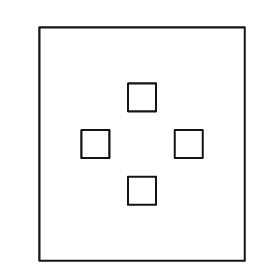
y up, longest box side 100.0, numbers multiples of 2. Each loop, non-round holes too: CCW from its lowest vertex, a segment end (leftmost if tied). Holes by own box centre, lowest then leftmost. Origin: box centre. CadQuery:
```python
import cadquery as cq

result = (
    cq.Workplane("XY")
    .moveTo(-44.0, -50.0)
    .lineTo(44.0, -50.0)
    .lineTo(44.0, 50.0)
    .lineTo(-44.0, 50.0)
    .close()
    .moveTo(-6.0, -26.0)
    .lineTo(6.0, -26.0)
    .lineTo(6.0, -14.0)
    .lineTo(-6.0, -14.0)
    .close()
    .moveTo(-26.0, -6.0)
    .lineTo(-14.0, -6.0)
    .lineTo(-14.0, 6.0)
    .lineTo(-26.0, 6.0)
    .close()
    .moveTo(14.0, -6.0)
    .lineTo(26.0, -6.0)
    .lineTo(26.0, 6.0)
    .lineTo(14.0, 6.0)
    .close()
    .moveTo(-6.0, 14.0)
    .lineTo(6.0, 14.0)
    .lineTo(6.0, 26.0)
    .lineTo(-6.0, 26.0)
    .close()
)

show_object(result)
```